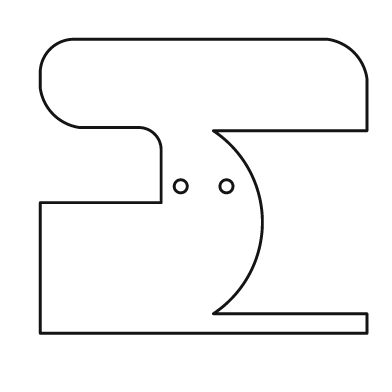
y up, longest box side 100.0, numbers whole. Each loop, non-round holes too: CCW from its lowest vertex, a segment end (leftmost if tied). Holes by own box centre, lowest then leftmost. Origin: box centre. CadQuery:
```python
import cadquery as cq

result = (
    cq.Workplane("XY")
    .moveTo(-50.0, -45.0)
    .lineTo(50.0, -45.0)
    .lineTo(50.0, -39.0)
    .lineTo(3.0, -39.0)
    .threePointArc((18.0, -11.0), (3.0, 17.0))
    .lineTo(50.0, 17.0)
    .lineTo(50.0, 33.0)
    .threePointArc((46.0, 41.0), (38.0, 45.0))
    .lineTo(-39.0, 45.0)
    .threePointArc((-47.0, 42.0), (-50.0, 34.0))
    .lineTo(-50.0, 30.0)
    .threePointArc((-46.0, 22.0), (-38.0, 18.0))
    .lineTo(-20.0, 18.0)
    .threePointArc((-15.0, 16.0), (-13.0, 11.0))
    .lineTo(-13.0, -5.0)
    .lineTo(-50.0, -5.0)
    .close()
    .moveTo(-7.0, 0.0)
    .circle(2.0)
    .moveTo(7.0, 0.0)
    .circle(2.0)
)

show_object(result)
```